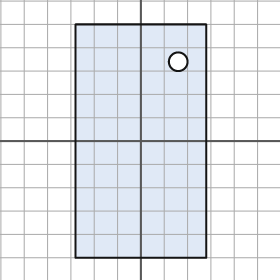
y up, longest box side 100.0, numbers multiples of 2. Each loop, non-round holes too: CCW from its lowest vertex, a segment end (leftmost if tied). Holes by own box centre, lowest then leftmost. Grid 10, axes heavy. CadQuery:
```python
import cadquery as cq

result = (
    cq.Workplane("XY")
    .moveTo(-28.0, -50.0)
    .lineTo(28.0, -50.0)
    .lineTo(28.0, 50.0)
    .lineTo(-28.0, 50.0)
    .close()
    .moveTo(16.0, 34.0)
    .circle(4.0)
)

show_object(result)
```